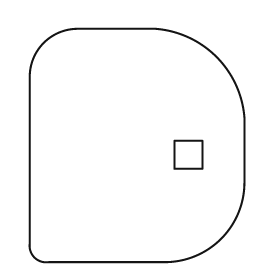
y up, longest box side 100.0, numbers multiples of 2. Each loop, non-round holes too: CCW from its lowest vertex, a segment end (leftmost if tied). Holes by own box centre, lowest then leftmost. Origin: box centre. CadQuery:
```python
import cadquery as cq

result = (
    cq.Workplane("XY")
    .moveTo(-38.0, -50.0)
    .lineTo(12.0, -50.0)
    .threePointArc((36.0, -40.0), (46.0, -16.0))
    .lineTo(46.0, 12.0)
    .threePointArc((34.0, 38.0), (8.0, 50.0))
    .lineTo(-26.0, 50.0)
    .threePointArc((-40.0, 44.0), (-46.0, 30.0))
    .lineTo(-46.0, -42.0)
    .threePointArc((-44.0, -48.0), (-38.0, -50.0))
    .close()
    .moveTo(16.0, -10.0)
    .lineTo(28.0, -10.0)
    .lineTo(28.0, 2.0)
    .lineTo(16.0, 2.0)
    .close()
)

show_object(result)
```